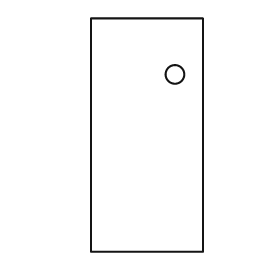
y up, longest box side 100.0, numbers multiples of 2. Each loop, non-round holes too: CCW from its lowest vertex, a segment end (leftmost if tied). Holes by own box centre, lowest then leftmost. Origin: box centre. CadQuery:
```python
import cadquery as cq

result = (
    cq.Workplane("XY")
    .moveTo(-24.0, -50.0)
    .lineTo(24.0, -50.0)
    .lineTo(24.0, 50.0)
    .lineTo(-24.0, 50.0)
    .close()
    .moveTo(12.0, 26.0)
    .circle(4.0)
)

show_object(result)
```